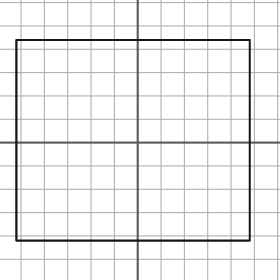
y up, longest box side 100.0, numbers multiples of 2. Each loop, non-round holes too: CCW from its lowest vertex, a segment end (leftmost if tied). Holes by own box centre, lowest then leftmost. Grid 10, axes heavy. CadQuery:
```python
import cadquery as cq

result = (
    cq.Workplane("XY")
    .moveTo(-52.0, -42.0)
    .lineTo(48.0, -42.0)
    .lineTo(48.0, 44.0)
    .lineTo(-52.0, 44.0)
    .close()
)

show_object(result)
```